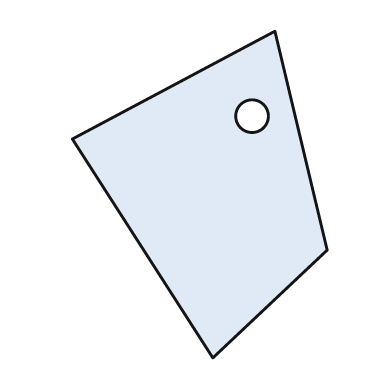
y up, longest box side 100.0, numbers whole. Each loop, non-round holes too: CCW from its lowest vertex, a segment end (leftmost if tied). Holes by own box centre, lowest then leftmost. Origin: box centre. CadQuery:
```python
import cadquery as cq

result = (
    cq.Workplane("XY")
    .moveTo(4.0, -50.0)
    .lineTo(39.0, -17.0)
    .lineTo(23.0, 50.0)
    .lineTo(-39.0, 17.0)
    .close()
    .moveTo(16.0, 24.0)
    .circle(5.0)
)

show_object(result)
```